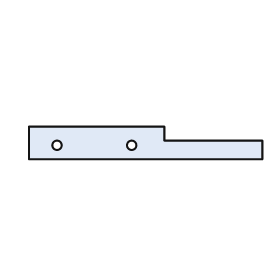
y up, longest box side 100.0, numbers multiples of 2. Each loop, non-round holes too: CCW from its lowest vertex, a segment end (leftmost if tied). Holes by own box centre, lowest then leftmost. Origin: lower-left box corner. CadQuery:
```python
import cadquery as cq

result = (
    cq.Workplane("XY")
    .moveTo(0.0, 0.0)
    .lineTo(100.0, 0.0)
    .lineTo(100.0, 8.0)
    .lineTo(58.0, 8.0)
    .lineTo(58.0, 14.0)
    .lineTo(0.0, 14.0)
    .close()
    .moveTo(12.0, 6.0)
    .circle(2.0)
    .moveTo(44.0, 6.0)
    .circle(2.0)
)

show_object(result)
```